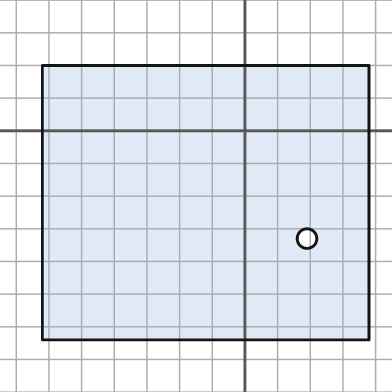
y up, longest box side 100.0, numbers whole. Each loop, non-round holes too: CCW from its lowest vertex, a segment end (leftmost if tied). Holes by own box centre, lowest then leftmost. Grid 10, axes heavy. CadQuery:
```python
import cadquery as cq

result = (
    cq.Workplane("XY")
    .moveTo(-62.0, -64.0)
    .lineTo(38.0, -64.0)
    .lineTo(38.0, 20.0)
    .lineTo(-62.0, 20.0)
    .close()
    .moveTo(19.0, -33.0)
    .circle(3.0)
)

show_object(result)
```